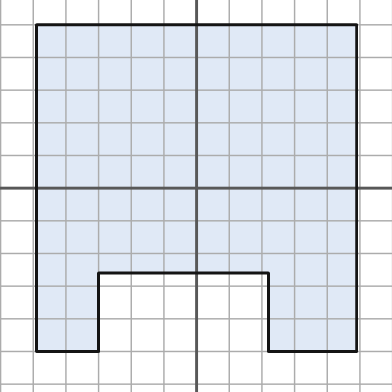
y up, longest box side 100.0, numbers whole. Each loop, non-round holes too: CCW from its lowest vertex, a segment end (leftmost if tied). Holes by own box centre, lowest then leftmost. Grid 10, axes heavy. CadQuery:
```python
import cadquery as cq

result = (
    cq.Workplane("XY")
    .moveTo(-49.0, -50.0)
    .lineTo(-30.0, -50.0)
    .lineTo(-30.0, -26.0)
    .lineTo(22.0, -26.0)
    .lineTo(22.0, -50.0)
    .lineTo(49.0, -50.0)
    .lineTo(49.0, 50.0)
    .lineTo(-49.0, 50.0)
    .close()
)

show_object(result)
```